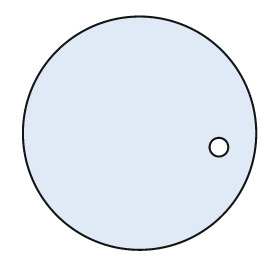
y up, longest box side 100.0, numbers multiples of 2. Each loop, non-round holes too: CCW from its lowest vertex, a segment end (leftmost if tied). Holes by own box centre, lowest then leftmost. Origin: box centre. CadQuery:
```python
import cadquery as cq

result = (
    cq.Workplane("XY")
    .moveTo(0.0, 0.0)
    .circle(50.0)
    .moveTo(34.0, -6.0)
    .circle(4.0)
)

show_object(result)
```